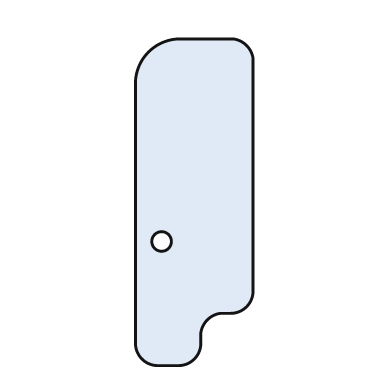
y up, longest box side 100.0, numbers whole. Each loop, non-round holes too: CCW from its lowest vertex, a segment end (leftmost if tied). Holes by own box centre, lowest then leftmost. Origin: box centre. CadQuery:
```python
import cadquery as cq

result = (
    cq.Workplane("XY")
    .moveTo(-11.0, -50.0)
    .lineTo(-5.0, -50.0)
    .threePointArc((0.0, -48.0), (2.0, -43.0))
    .lineTo(2.0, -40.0)
    .threePointArc((4.0, -36.0), (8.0, -34.0))
    .lineTo(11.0, -34.0)
    .threePointArc((16.0, -32.0), (18.0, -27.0))
    .lineTo(18.0, 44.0)
    .threePointArc((16.0, 48.0), (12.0, 50.0))
    .lineTo(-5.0, 50.0)
    .threePointArc((-14.0, 46.0), (-18.0, 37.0))
    .lineTo(-18.0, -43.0)
    .threePointArc((-16.0, -48.0), (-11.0, -50.0))
    .close()
    .moveTo(-10.0, -12.0)
    .circle(3.0)
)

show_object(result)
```